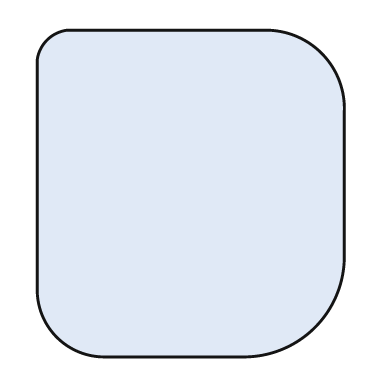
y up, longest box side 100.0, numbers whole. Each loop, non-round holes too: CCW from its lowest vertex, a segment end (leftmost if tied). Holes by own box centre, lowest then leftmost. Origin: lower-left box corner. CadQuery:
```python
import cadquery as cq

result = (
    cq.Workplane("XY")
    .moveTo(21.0, 0.0)
    .lineTo(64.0, 0.0)
    .threePointArc((85.0, 9.0), (94.0, 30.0))
    .lineTo(94.0, 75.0)
    .threePointArc((87.0, 93.0), (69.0, 100.0))
    .lineTo(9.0, 100.0)
    .threePointArc((3.0, 97.0), (0.0, 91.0))
    .lineTo(0.0, 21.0)
    .threePointArc((6.0, 6.0), (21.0, 0.0))
    .close()
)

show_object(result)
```